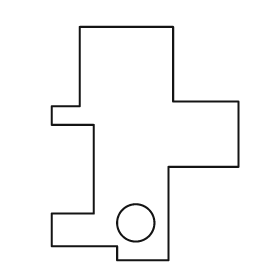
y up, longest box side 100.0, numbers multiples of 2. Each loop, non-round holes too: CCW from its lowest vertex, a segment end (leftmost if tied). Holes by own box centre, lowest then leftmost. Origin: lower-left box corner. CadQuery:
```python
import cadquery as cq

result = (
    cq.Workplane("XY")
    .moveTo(28.0, 0.0)
    .lineTo(50.0, 0.0)
    .lineTo(50.0, 40.0)
    .lineTo(80.0, 40.0)
    .lineTo(80.0, 68.0)
    .lineTo(52.0, 68.0)
    .lineTo(52.0, 100.0)
    .lineTo(12.0, 100.0)
    .lineTo(12.0, 66.0)
    .lineTo(0.0, 66.0)
    .lineTo(0.0, 58.0)
    .lineTo(18.0, 58.0)
    .lineTo(18.0, 20.0)
    .lineTo(0.0, 20.0)
    .lineTo(0.0, 6.0)
    .lineTo(28.0, 6.0)
    .close()
    .moveTo(36.0, 16.0)
    .circle(8.0)
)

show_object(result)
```